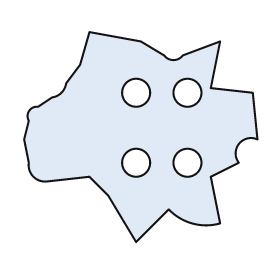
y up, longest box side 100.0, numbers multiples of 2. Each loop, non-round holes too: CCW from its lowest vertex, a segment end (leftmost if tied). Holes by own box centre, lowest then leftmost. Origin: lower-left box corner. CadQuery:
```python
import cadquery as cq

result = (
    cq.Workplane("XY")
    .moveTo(48.0, 0.0)
    .lineTo(62.0, 14.0)
    .threePointArc((72.0, 8.0), (84.0, 8.0))
    .lineTo(80.0, 28.0)
    .lineTo(92.0, 34.0)
    .threePointArc((92.0, 42.0), (100.0, 44.0))
    .lineTo(98.0, 64.0)
    .lineTo(80.0, 66.0)
    .lineTo(84.0, 86.0)
    .lineTo(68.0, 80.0)
    .threePointArc((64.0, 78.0), (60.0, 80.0))
    .lineTo(50.0, 86.0)
    .lineTo(28.0, 90.0)
    .lineTo(24.0, 76.0)
    .lineTo(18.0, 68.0)
    .threePointArc((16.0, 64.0), (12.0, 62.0))
    .lineTo(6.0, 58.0)
    .threePointArc((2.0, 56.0), (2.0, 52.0))
    .lineTo(0.0, 44.0)
    .lineTo(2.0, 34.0)
    .threePointArc((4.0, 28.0), (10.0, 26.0))
    .lineTo(28.0, 28.0)
    .lineTo(36.0, 20.0)
    .close()
    .moveTo(48.0, 34.0)
    .circle(6.0)
    .moveTo(70.0, 34.0)
    .circle(6.0)
    .moveTo(48.0, 64.0)
    .circle(6.0)
    .moveTo(70.0, 64.0)
    .circle(6.0)
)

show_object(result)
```